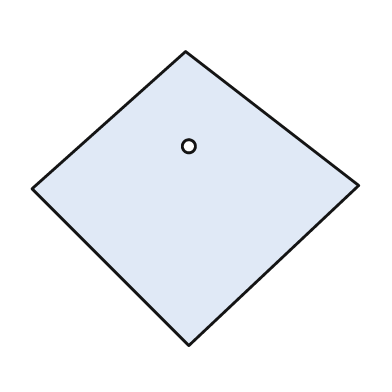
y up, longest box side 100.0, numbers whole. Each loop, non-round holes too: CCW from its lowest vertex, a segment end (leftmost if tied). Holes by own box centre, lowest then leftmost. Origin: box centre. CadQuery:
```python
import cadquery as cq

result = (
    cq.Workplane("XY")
    .moveTo(-2.0, -45.0)
    .lineTo(50.0, 4.0)
    .lineTo(-3.0, 45.0)
    .lineTo(-50.0, 3.0)
    .close()
    .moveTo(-2.0, 16.0)
    .circle(2.0)
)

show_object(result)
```